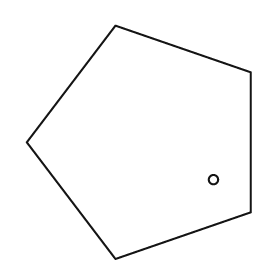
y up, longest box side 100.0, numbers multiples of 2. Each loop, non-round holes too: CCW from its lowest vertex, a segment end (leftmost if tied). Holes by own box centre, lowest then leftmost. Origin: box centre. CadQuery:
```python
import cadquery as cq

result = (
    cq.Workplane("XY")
    .moveTo(-10.0, -50.0)
    .lineTo(48.0, -30.0)
    .lineTo(48.0, 30.0)
    .lineTo(-10.0, 50.0)
    .lineTo(-48.0, 0.0)
    .close()
    .moveTo(32.0, -16.0)
    .circle(2.0)
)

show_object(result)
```